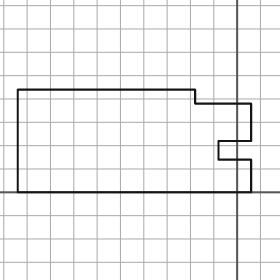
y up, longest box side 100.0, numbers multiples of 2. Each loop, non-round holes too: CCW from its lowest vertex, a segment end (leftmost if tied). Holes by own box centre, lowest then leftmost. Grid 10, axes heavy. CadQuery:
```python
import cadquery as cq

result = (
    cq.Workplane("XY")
    .moveTo(-94.0, 0.0)
    .lineTo(6.0, 0.0)
    .lineTo(6.0, 14.0)
    .lineTo(-8.0, 14.0)
    .lineTo(-8.0, 22.0)
    .lineTo(6.0, 22.0)
    .lineTo(6.0, 38.0)
    .lineTo(-18.0, 38.0)
    .lineTo(-18.0, 44.0)
    .lineTo(-94.0, 44.0)
    .close()
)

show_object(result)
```